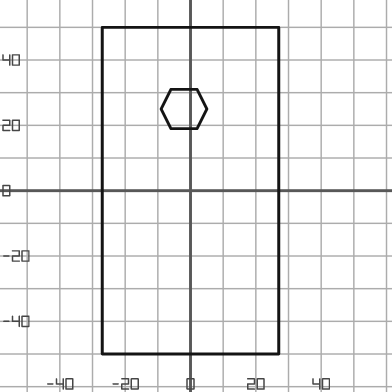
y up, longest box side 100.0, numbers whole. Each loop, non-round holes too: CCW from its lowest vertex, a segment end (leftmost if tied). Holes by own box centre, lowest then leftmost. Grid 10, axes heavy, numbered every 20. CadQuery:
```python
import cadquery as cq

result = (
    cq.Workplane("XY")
    .moveTo(-27.0, -50.0)
    .lineTo(27.0, -50.0)
    .lineTo(27.0, 50.0)
    .lineTo(-27.0, 50.0)
    .close()
    .moveTo(-6.0, 19.0)
    .lineTo(2.0, 19.0)
    .lineTo(5.0, 25.0)
    .lineTo(2.0, 31.0)
    .lineTo(-6.0, 31.0)
    .lineTo(-9.0, 25.0)
    .close()
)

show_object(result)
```